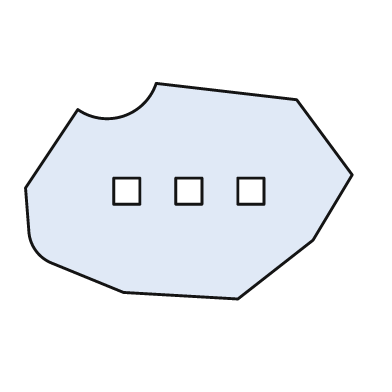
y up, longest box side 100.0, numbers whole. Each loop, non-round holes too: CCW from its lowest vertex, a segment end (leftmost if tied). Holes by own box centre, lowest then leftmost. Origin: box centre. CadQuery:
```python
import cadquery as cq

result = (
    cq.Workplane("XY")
    .moveTo(15.0, -33.0)
    .lineTo(38.0, -15.0)
    .lineTo(50.0, 5.0)
    .lineTo(33.0, 28.0)
    .lineTo(-10.0, 33.0)
    .threePointArc((-20.0, 23.0), (-34.0, 25.0))
    .lineTo(-50.0, 1.0)
    .lineTo(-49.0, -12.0)
    .threePointArc((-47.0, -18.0), (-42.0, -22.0))
    .lineTo(-20.0, -31.0)
    .close()
    .moveTo(-23.0, -4.0)
    .lineTo(-15.0, -4.0)
    .lineTo(-15.0, 4.0)
    .lineTo(-23.0, 4.0)
    .close()
    .moveTo(-4.0, -4.0)
    .lineTo(4.0, -4.0)
    .lineTo(4.0, 4.0)
    .lineTo(-4.0, 4.0)
    .close()
    .moveTo(15.0, -4.0)
    .lineTo(23.0, -4.0)
    .lineTo(23.0, 4.0)
    .lineTo(15.0, 4.0)
    .close()
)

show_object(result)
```